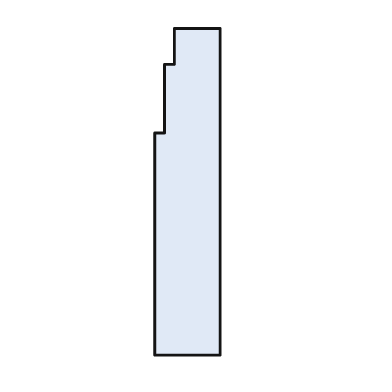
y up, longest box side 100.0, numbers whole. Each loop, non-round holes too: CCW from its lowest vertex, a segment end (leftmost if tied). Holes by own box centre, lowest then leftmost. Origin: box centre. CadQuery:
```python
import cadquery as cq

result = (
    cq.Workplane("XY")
    .moveTo(-10.0, -50.0)
    .lineTo(10.0, -50.0)
    .lineTo(10.0, 50.0)
    .lineTo(-4.0, 50.0)
    .lineTo(-4.0, 39.0)
    .lineTo(-7.0, 39.0)
    .lineTo(-7.0, 18.0)
    .lineTo(-10.0, 18.0)
    .close()
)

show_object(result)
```